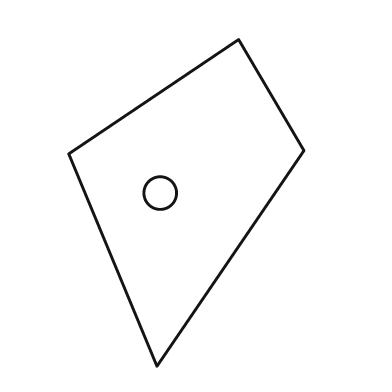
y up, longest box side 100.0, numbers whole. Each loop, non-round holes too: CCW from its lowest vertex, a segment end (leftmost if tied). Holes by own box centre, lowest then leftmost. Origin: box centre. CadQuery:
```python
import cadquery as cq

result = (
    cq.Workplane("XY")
    .moveTo(-9.0, -50.0)
    .lineTo(36.0, 16.0)
    .lineTo(16.0, 50.0)
    .lineTo(-36.0, 15.0)
    .close()
    .moveTo(-8.0, 3.0)
    .circle(5.0)
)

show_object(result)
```